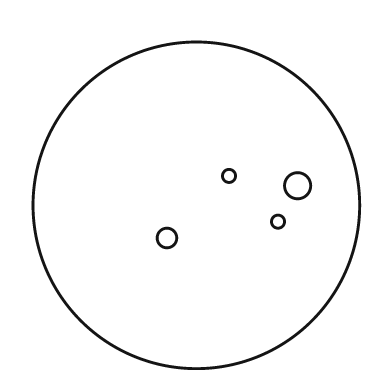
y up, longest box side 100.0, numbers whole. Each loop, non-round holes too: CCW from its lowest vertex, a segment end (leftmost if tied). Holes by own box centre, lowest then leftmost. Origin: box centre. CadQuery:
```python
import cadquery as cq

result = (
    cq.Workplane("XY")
    .moveTo(0.0, 0.0)
    .circle(50.0)
    .moveTo(-9.0, -10.0)
    .circle(3.0)
    .moveTo(25.0, -5.0)
    .circle(2.0)
    .moveTo(31.0, 6.0)
    .circle(4.0)
    .moveTo(10.0, 9.0)
    .circle(2.0)
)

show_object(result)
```